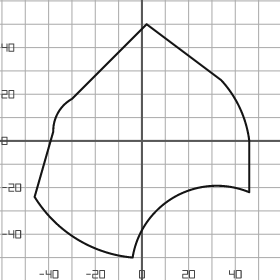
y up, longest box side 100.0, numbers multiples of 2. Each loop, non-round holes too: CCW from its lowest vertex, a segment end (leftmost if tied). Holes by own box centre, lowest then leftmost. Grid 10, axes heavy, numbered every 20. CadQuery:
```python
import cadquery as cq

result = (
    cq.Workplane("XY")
    .moveTo(-4.0, -50.0)
    .threePointArc((14.0, -24.0), (46.0, -22.0))
    .lineTo(46.0, 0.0)
    .threePointArc((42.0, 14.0), (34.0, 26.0))
    .lineTo(2.0, 50.0)
    .lineTo(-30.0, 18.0)
    .threePointArc((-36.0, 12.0), (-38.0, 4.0))
    .lineTo(-46.0, -24.0)
    .threePointArc((-28.0, -42.0), (-4.0, -50.0))
    .close()
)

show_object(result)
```